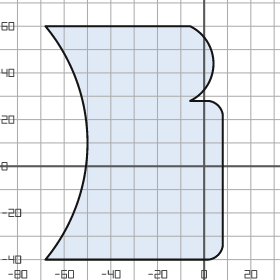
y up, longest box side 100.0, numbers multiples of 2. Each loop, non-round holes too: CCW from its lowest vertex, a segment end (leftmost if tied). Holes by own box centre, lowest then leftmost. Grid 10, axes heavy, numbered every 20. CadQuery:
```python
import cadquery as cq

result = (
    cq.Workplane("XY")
    .moveTo(-68.0, -40.0)
    .lineTo(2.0, -40.0)
    .threePointArc((6.0, -38.0), (8.0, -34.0))
    .lineTo(8.0, 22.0)
    .threePointArc((6.0, 26.0), (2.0, 28.0))
    .lineTo(-6.0, 28.0)
    .threePointArc((4.0, 44.0), (-6.0, 60.0))
    .lineTo(-68.0, 60.0)
    .threePointArc((-50.0, 10.0), (-68.0, -40.0))
    .close()
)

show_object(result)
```